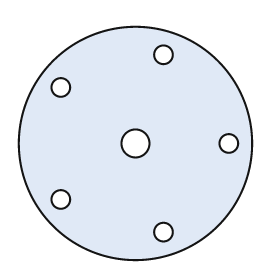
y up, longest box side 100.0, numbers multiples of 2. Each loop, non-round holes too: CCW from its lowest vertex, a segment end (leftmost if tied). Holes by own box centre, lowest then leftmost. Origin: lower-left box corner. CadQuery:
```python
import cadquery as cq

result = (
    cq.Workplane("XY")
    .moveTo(50.0, 50.0)
    .circle(50.0)
    .moveTo(62.0, 12.0)
    .circle(4.0)
    .moveTo(18.0, 26.0)
    .circle(4.0)
    .moveTo(50.0, 50.0)
    .circle(6.0)
    .moveTo(90.0, 50.0)
    .circle(4.0)
    .moveTo(18.0, 74.0)
    .circle(4.0)
    .moveTo(62.0, 88.0)
    .circle(4.0)
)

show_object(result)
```